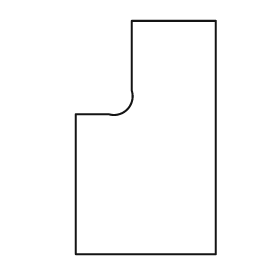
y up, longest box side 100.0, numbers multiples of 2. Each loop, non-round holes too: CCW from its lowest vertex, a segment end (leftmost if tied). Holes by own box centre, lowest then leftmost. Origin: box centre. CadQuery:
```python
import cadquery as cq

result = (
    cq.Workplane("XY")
    .moveTo(-30.0, -50.0)
    .lineTo(30.0, -50.0)
    .lineTo(30.0, 50.0)
    .lineTo(-6.0, 50.0)
    .lineTo(-6.0, 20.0)
    .threePointArc((-8.0, 12.0), (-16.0, 10.0))
    .lineTo(-30.0, 10.0)
    .close()
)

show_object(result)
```